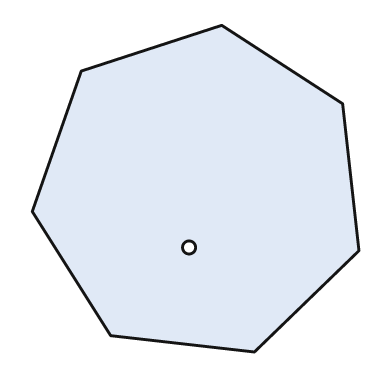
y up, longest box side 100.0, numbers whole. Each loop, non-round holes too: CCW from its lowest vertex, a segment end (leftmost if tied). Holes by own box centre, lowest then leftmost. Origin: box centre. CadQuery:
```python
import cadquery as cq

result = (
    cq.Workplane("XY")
    .moveTo(18.0, -50.0)
    .lineTo(50.0, -19.0)
    .lineTo(45.0, 26.0)
    .lineTo(8.0, 50.0)
    .lineTo(-35.0, 36.0)
    .lineTo(-50.0, -7.0)
    .lineTo(-26.0, -45.0)
    .close()
    .moveTo(-2.0, -18.0)
    .circle(2.0)
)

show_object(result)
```